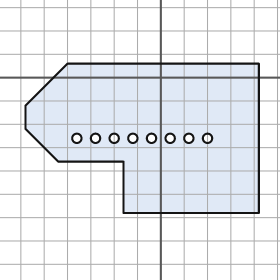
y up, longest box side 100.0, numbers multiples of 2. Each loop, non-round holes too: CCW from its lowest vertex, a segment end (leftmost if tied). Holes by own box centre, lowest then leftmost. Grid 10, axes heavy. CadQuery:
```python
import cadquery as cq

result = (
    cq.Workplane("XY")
    .moveTo(-16.0, -58.0)
    .lineTo(42.0, -58.0)
    .lineTo(42.0, 6.0)
    .lineTo(-40.0, 6.0)
    .lineTo(-58.0, -12.0)
    .lineTo(-58.0, -22.0)
    .lineTo(-44.0, -36.0)
    .lineTo(-16.0, -36.0)
    .close()
    .moveTo(-36.0, -26.0)
    .circle(2.0)
    .moveTo(-28.0, -26.0)
    .circle(2.0)
    .moveTo(-20.0, -26.0)
    .circle(2.0)
    .moveTo(-12.0, -26.0)
    .circle(2.0)
    .moveTo(-4.0, -26.0)
    .circle(2.0)
    .moveTo(4.0, -26.0)
    .circle(2.0)
    .moveTo(12.0, -26.0)
    .circle(2.0)
    .moveTo(20.0, -26.0)
    .circle(2.0)
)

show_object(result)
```